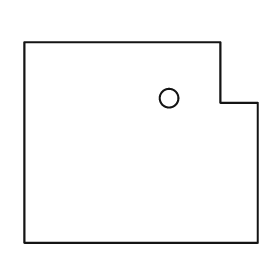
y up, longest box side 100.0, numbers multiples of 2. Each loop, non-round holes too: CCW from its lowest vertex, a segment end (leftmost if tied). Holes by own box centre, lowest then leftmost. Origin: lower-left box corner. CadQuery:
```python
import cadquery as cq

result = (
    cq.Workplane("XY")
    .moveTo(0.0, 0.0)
    .lineTo(100.0, 0.0)
    .lineTo(100.0, 60.0)
    .lineTo(84.0, 60.0)
    .lineTo(84.0, 86.0)
    .lineTo(0.0, 86.0)
    .close()
    .moveTo(62.0, 62.0)
    .circle(4.0)
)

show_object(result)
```